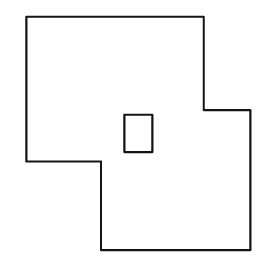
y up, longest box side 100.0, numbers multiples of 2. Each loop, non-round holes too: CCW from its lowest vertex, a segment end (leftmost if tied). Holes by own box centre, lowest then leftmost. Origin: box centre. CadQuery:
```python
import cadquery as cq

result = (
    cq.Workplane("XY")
    .moveTo(-16.0, -50.0)
    .lineTo(48.0, -50.0)
    .lineTo(48.0, 10.0)
    .lineTo(28.0, 10.0)
    .lineTo(28.0, 50.0)
    .lineTo(-48.0, 50.0)
    .lineTo(-48.0, -12.0)
    .lineTo(-16.0, -12.0)
    .close()
    .moveTo(-6.0, -8.0)
    .lineTo(6.0, -8.0)
    .lineTo(6.0, 8.0)
    .lineTo(-6.0, 8.0)
    .close()
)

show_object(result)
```